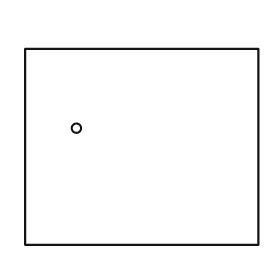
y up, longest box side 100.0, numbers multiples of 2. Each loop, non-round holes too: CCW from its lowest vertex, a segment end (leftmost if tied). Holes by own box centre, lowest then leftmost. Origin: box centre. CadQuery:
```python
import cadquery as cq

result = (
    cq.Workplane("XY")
    .moveTo(-50.0, -42.0)
    .lineTo(50.0, -42.0)
    .lineTo(50.0, 42.0)
    .lineTo(-50.0, 42.0)
    .close()
    .moveTo(-28.0, 8.0)
    .circle(2.0)
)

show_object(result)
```